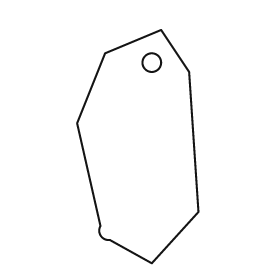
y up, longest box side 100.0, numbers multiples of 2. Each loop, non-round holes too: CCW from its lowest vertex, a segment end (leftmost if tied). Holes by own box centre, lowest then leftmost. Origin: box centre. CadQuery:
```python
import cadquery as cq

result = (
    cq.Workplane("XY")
    .moveTo(6.0, -50.0)
    .lineTo(26.0, -28.0)
    .lineTo(22.0, 32.0)
    .lineTo(10.0, 50.0)
    .lineTo(-14.0, 40.0)
    .lineTo(-26.0, 10.0)
    .lineTo(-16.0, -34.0)
    .threePointArc((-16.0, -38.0), (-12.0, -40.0))
    .close()
    .moveTo(6.0, 36.0)
    .circle(4.0)
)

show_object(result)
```